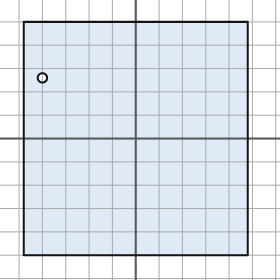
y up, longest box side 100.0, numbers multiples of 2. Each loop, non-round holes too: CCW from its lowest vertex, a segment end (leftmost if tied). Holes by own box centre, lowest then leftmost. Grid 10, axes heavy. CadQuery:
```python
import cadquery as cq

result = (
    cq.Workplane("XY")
    .moveTo(-48.0, -50.0)
    .lineTo(48.0, -50.0)
    .lineTo(48.0, 50.0)
    .lineTo(-48.0, 50.0)
    .close()
    .moveTo(-40.0, 26.0)
    .circle(2.0)
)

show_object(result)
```